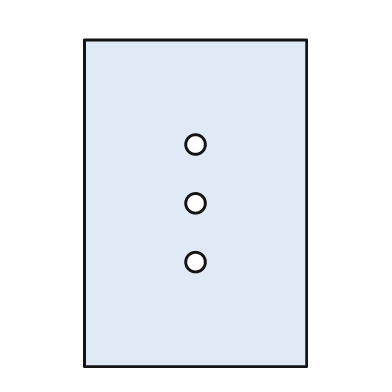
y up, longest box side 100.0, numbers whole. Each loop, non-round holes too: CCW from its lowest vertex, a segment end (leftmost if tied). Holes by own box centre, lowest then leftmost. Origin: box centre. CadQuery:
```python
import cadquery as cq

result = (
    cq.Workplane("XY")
    .moveTo(-34.0, -50.0)
    .lineTo(34.0, -50.0)
    .lineTo(34.0, 50.0)
    .lineTo(-34.0, 50.0)
    .close()
    .moveTo(0.0, -18.0)
    .circle(3.0)
    .moveTo(0.0, 0.0)
    .circle(3.0)
    .moveTo(0.0, 18.0)
    .circle(3.0)
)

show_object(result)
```